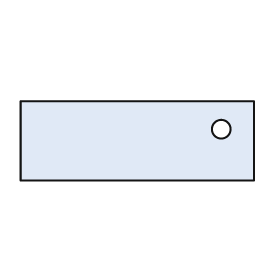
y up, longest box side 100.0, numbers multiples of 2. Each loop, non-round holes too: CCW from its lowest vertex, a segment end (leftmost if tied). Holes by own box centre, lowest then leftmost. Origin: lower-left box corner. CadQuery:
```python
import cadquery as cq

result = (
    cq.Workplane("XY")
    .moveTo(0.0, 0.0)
    .lineTo(100.0, 0.0)
    .lineTo(100.0, 34.0)
    .lineTo(0.0, 34.0)
    .close()
    .moveTo(86.0, 22.0)
    .circle(4.0)
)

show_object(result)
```